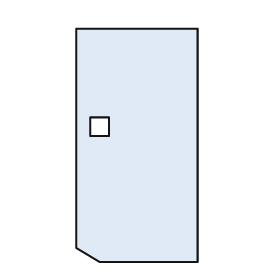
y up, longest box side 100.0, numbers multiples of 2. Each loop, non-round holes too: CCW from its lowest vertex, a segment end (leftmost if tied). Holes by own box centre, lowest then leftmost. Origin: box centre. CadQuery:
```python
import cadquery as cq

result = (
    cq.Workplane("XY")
    .moveTo(-16.0, -50.0)
    .lineTo(26.0, -50.0)
    .lineTo(26.0, 50.0)
    .lineTo(-26.0, 50.0)
    .lineTo(-26.0, -44.0)
    .close()
    .moveTo(-20.0, 4.0)
    .lineTo(-12.0, 4.0)
    .lineTo(-12.0, 12.0)
    .lineTo(-20.0, 12.0)
    .close()
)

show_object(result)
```